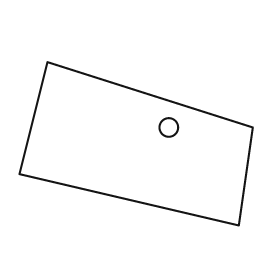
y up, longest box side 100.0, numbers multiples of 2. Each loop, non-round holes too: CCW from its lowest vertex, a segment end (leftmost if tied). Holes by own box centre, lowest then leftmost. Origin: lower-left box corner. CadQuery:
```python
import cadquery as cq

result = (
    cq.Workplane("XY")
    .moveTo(94.0, 0.0)
    .lineTo(100.0, 42.0)
    .lineTo(12.0, 70.0)
    .lineTo(0.0, 22.0)
    .close()
    .moveTo(64.0, 42.0)
    .circle(4.0)
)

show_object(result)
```